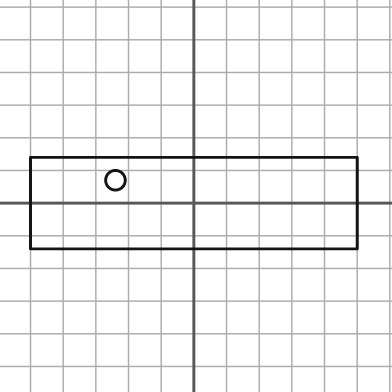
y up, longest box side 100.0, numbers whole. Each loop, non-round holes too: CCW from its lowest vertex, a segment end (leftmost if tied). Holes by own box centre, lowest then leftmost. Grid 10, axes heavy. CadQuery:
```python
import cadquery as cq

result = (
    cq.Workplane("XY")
    .moveTo(-50.0, -14.0)
    .lineTo(50.0, -14.0)
    .lineTo(50.0, 14.0)
    .lineTo(-50.0, 14.0)
    .close()
    .moveTo(-24.0, 7.0)
    .circle(3.0)
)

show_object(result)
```